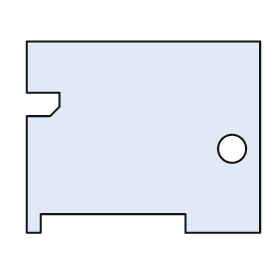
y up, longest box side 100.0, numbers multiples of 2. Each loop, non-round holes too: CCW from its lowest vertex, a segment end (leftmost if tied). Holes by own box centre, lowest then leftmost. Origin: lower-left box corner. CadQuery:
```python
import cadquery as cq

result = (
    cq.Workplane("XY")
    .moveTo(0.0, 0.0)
    .lineTo(6.0, 0.0)
    .lineTo(6.0, 8.0)
    .lineTo(68.0, 8.0)
    .lineTo(68.0, 0.0)
    .lineTo(100.0, 0.0)
    .lineTo(100.0, 82.0)
    .lineTo(0.0, 82.0)
    .lineTo(0.0, 60.0)
    .lineTo(14.0, 60.0)
    .lineTo(14.0, 54.0)
    .lineTo(10.0, 50.0)
    .lineTo(0.0, 50.0)
    .close()
    .moveTo(88.0, 36.0)
    .circle(6.0)
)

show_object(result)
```